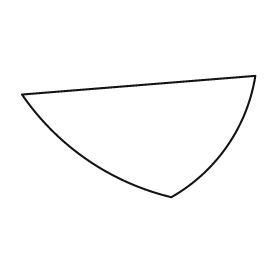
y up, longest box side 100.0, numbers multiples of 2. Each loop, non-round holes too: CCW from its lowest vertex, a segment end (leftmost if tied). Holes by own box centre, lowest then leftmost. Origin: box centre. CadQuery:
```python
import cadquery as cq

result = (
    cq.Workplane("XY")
    .moveTo(14.0, -26.0)
    .threePointArc((38.0, -4.0), (50.0, 26.0))
    .lineTo(-50.0, 18.0)
    .threePointArc((-22.0, -10.0), (14.0, -26.0))
    .close()
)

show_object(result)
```